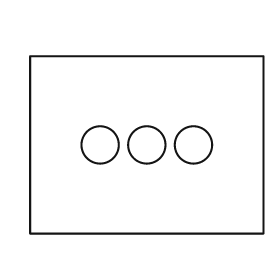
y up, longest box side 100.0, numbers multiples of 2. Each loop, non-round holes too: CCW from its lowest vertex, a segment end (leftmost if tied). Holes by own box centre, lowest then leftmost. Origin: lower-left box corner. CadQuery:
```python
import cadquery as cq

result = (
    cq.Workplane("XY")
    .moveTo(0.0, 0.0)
    .lineTo(100.0, 0.0)
    .lineTo(100.0, 76.0)
    .lineTo(0.0, 76.0)
    .close()
    .moveTo(30.0, 38.0)
    .circle(8.0)
    .moveTo(50.0, 38.0)
    .circle(8.0)
    .moveTo(70.0, 38.0)
    .circle(8.0)
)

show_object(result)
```